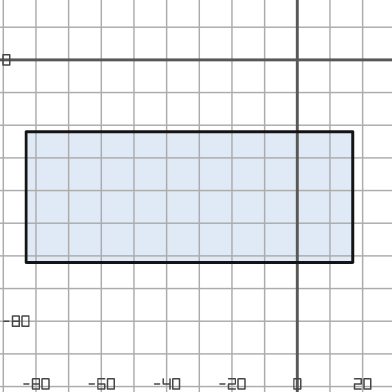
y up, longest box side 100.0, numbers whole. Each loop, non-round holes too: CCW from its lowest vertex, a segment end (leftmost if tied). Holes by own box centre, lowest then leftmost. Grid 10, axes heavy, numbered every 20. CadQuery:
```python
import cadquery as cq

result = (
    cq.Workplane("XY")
    .moveTo(-83.0, -62.0)
    .lineTo(17.0, -62.0)
    .lineTo(17.0, -22.0)
    .lineTo(-83.0, -22.0)
    .close()
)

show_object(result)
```